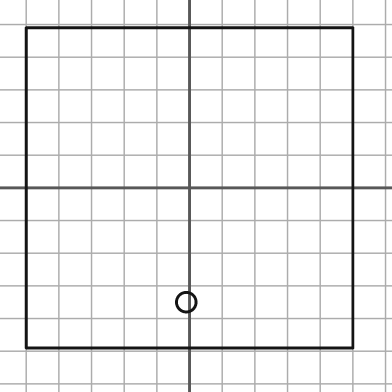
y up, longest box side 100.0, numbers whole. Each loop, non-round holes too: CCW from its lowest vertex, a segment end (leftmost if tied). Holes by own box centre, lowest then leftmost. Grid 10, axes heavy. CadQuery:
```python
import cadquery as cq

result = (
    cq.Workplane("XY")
    .moveTo(-50.0, -49.0)
    .lineTo(50.0, -49.0)
    .lineTo(50.0, 49.0)
    .lineTo(-50.0, 49.0)
    .close()
    .moveTo(-1.0, -35.0)
    .circle(3.0)
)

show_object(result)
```